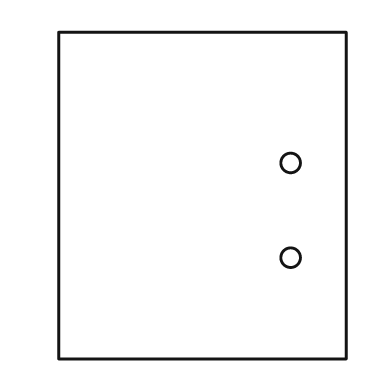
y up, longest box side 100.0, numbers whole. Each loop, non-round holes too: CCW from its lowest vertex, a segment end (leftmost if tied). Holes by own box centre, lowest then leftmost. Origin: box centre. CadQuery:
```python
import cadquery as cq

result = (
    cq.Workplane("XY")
    .moveTo(-44.0, -50.0)
    .lineTo(44.0, -50.0)
    .lineTo(44.0, 50.0)
    .lineTo(-44.0, 50.0)
    .close()
    .moveTo(27.0, -19.0)
    .circle(3.0)
    .moveTo(27.0, 10.0)
    .circle(3.0)
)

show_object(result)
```